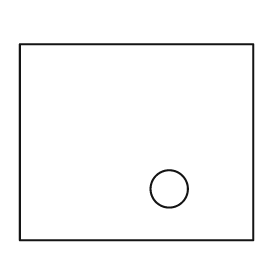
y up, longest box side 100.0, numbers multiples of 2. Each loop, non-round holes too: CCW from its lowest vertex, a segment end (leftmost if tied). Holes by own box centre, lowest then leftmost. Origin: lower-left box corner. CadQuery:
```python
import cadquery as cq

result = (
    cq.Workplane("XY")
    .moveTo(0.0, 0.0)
    .lineTo(100.0, 0.0)
    .lineTo(100.0, 84.0)
    .lineTo(0.0, 84.0)
    .close()
    .moveTo(64.0, 22.0)
    .circle(8.0)
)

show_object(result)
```